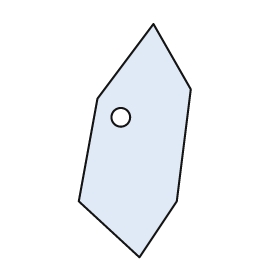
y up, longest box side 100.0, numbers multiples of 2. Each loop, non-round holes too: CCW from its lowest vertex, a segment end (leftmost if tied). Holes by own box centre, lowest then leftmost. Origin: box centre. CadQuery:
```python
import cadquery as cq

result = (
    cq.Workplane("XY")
    .moveTo(2.0, -50.0)
    .lineTo(18.0, -26.0)
    .lineTo(24.0, 22.0)
    .lineTo(8.0, 50.0)
    .lineTo(-16.0, 18.0)
    .lineTo(-24.0, -26.0)
    .close()
    .moveTo(-6.0, 10.0)
    .circle(4.0)
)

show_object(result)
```